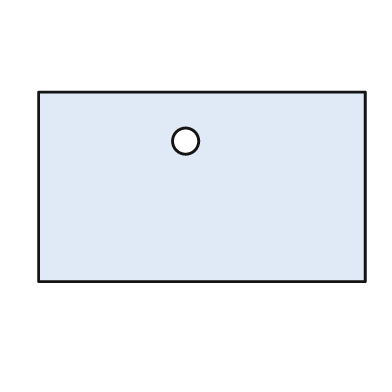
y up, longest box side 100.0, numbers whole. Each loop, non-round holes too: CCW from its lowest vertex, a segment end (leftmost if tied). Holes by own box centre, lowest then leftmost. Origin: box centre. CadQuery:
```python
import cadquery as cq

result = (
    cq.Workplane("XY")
    .moveTo(-50.0, -29.0)
    .lineTo(50.0, -29.0)
    .lineTo(50.0, 29.0)
    .lineTo(-50.0, 29.0)
    .close()
    .moveTo(-5.0, 14.0)
    .circle(4.0)
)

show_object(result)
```